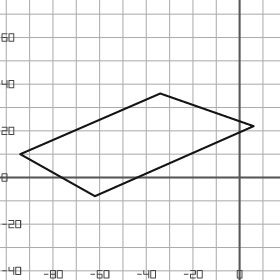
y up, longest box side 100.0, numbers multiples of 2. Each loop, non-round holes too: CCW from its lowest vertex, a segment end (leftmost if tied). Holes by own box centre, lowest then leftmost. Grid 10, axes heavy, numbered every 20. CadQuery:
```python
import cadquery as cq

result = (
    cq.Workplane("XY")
    .moveTo(-62.0, -8.0)
    .lineTo(6.0, 22.0)
    .lineTo(-34.0, 36.0)
    .lineTo(-94.0, 10.0)
    .close()
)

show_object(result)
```